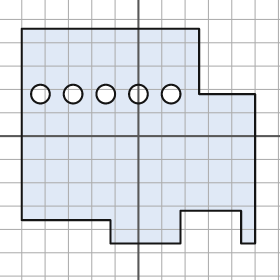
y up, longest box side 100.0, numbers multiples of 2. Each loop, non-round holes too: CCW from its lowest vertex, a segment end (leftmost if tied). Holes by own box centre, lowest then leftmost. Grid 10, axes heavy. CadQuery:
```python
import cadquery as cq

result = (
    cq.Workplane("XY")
    .moveTo(-12.0, -46.0)
    .lineTo(18.0, -46.0)
    .lineTo(18.0, -32.0)
    .lineTo(44.0, -32.0)
    .lineTo(44.0, -46.0)
    .lineTo(50.0, -46.0)
    .lineTo(50.0, 18.0)
    .lineTo(26.0, 18.0)
    .lineTo(26.0, 46.0)
    .lineTo(-50.0, 46.0)
    .lineTo(-50.0, -36.0)
    .lineTo(-12.0, -36.0)
    .close()
    .moveTo(-42.0, 18.0)
    .circle(4.0)
    .moveTo(-28.0, 18.0)
    .circle(4.0)
    .moveTo(-14.0, 18.0)
    .circle(4.0)
    .moveTo(0.0, 18.0)
    .circle(4.0)
    .moveTo(14.0, 18.0)
    .circle(4.0)
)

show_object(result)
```